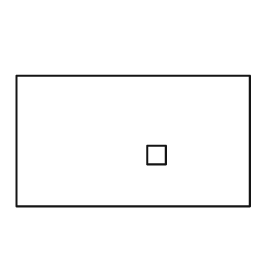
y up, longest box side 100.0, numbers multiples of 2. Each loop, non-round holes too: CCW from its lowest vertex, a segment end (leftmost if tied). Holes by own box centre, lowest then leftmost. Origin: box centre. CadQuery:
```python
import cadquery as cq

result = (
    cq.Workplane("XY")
    .moveTo(-50.0, -28.0)
    .lineTo(50.0, -28.0)
    .lineTo(50.0, 28.0)
    .lineTo(-50.0, 28.0)
    .close()
    .moveTo(6.0, -10.0)
    .lineTo(14.0, -10.0)
    .lineTo(14.0, -2.0)
    .lineTo(6.0, -2.0)
    .close()
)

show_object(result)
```